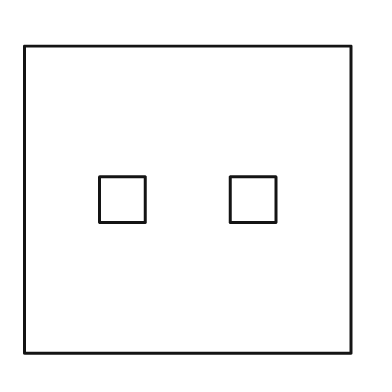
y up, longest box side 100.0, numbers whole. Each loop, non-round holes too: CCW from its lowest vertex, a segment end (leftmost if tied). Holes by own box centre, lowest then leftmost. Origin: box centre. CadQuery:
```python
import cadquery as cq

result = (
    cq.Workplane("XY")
    .moveTo(-50.0, -47.0)
    .lineTo(50.0, -47.0)
    .lineTo(50.0, 47.0)
    .lineTo(-50.0, 47.0)
    .close()
    .moveTo(-27.0, -7.0)
    .lineTo(-13.0, -7.0)
    .lineTo(-13.0, 7.0)
    .lineTo(-27.0, 7.0)
    .close()
    .moveTo(13.0, -7.0)
    .lineTo(27.0, -7.0)
    .lineTo(27.0, 7.0)
    .lineTo(13.0, 7.0)
    .close()
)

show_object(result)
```